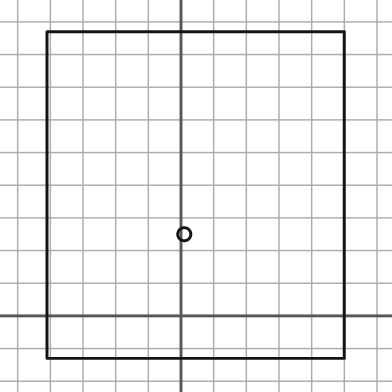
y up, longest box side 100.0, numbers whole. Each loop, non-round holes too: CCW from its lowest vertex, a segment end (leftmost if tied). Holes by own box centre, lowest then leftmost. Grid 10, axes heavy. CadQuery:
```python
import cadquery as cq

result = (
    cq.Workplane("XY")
    .moveTo(-41.0, -13.0)
    .lineTo(50.0, -13.0)
    .lineTo(50.0, 87.0)
    .lineTo(-41.0, 87.0)
    .close()
    .moveTo(1.0, 25.0)
    .circle(2.0)
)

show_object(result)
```